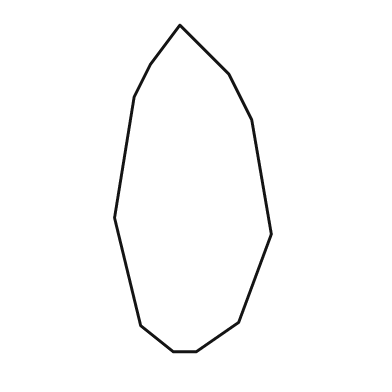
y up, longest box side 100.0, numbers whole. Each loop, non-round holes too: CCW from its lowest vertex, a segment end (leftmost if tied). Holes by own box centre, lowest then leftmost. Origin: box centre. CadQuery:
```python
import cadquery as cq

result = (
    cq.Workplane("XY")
    .moveTo(-6.0, -50.0)
    .lineTo(1.0, -50.0)
    .lineTo(14.0, -41.0)
    .lineTo(24.0, -14.0)
    .lineTo(18.0, 21.0)
    .lineTo(11.0, 35.0)
    .lineTo(-4.0, 50.0)
    .lineTo(-13.0, 38.0)
    .lineTo(-18.0, 28.0)
    .lineTo(-24.0, -9.0)
    .lineTo(-16.0, -42.0)
    .close()
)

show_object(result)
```